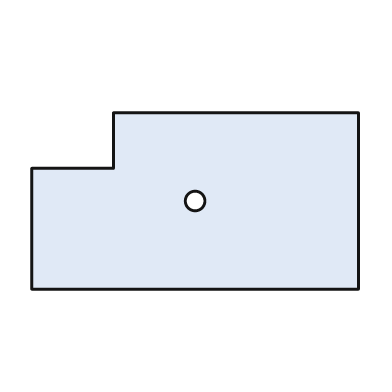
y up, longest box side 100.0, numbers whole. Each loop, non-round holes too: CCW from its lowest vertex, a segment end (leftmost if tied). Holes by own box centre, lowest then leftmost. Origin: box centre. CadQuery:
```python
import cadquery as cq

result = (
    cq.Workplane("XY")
    .moveTo(-50.0, -27.0)
    .lineTo(50.0, -27.0)
    .lineTo(50.0, 27.0)
    .lineTo(-25.0, 27.0)
    .lineTo(-25.0, 10.0)
    .lineTo(-50.0, 10.0)
    .close()
    .moveTo(0.0, 0.0)
    .circle(3.0)
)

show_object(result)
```